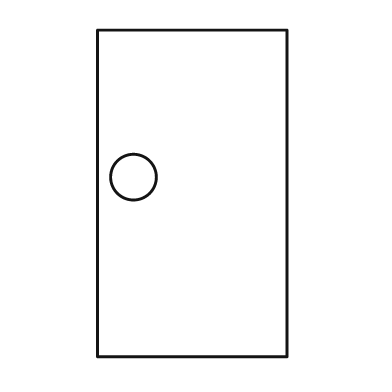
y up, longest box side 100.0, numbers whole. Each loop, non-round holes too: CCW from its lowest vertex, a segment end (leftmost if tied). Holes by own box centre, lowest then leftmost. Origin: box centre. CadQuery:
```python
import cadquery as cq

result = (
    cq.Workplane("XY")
    .moveTo(-29.0, -50.0)
    .lineTo(29.0, -50.0)
    .lineTo(29.0, 50.0)
    .lineTo(-29.0, 50.0)
    .close()
    .moveTo(-18.0, 5.0)
    .circle(7.0)
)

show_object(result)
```